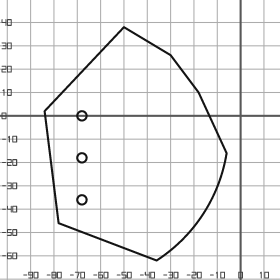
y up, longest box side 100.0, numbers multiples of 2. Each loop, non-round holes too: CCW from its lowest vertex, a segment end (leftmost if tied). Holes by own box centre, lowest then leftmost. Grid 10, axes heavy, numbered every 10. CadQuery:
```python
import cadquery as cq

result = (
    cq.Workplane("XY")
    .moveTo(-36.0, -62.0)
    .threePointArc((-16.0, -42.0), (-6.0, -16.0))
    .lineTo(-18.0, 10.0)
    .lineTo(-30.0, 26.0)
    .lineTo(-50.0, 38.0)
    .lineTo(-84.0, 2.0)
    .lineTo(-78.0, -46.0)
    .close()
    .moveTo(-68.0, -36.0)
    .circle(2.0)
    .moveTo(-68.0, -18.0)
    .circle(2.0)
    .moveTo(-68.0, 0.0)
    .circle(2.0)
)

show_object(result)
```